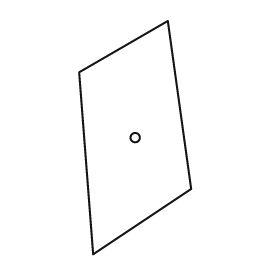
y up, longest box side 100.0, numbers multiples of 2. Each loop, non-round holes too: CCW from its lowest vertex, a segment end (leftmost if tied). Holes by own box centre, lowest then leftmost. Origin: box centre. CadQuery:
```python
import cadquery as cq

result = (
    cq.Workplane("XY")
    .moveTo(-18.0, -50.0)
    .lineTo(24.0, -22.0)
    .lineTo(14.0, 50.0)
    .lineTo(-24.0, 28.0)
    .close()
    .moveTo(0.0, 0.0)
    .circle(2.0)
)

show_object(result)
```